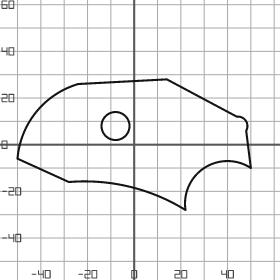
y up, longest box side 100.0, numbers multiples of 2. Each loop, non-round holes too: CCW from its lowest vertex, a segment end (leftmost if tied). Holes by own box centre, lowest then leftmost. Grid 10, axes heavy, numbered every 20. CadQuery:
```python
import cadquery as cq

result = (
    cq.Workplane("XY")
    .moveTo(22.0, -28.0)
    .threePointArc((30.0, -10.0), (50.0, -10.0))
    .lineTo(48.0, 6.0)
    .threePointArc((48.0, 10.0), (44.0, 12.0))
    .lineTo(14.0, 28.0)
    .lineTo(-24.0, 26.0)
    .threePointArc((-42.0, 14.0), (-50.0, -6.0))
    .lineTo(-28.0, -16.0)
    .threePointArc((-2.0, -18.0), (22.0, -28.0))
    .close()
    .moveTo(-8.0, 8.0)
    .circle(6.0)
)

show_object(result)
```